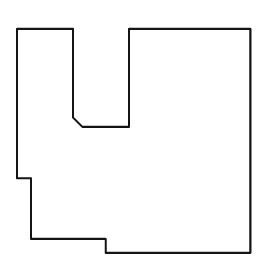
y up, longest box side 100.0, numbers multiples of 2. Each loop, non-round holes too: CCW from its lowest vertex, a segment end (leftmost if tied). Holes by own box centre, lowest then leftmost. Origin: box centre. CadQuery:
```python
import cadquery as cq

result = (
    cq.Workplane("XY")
    .moveTo(-12.0, -48.0)
    .lineTo(50.0, -48.0)
    .lineTo(50.0, 48.0)
    .lineTo(-2.0, 48.0)
    .lineTo(-2.0, 6.0)
    .lineTo(-22.0, 6.0)
    .lineTo(-26.0, 10.0)
    .lineTo(-26.0, 48.0)
    .lineTo(-50.0, 48.0)
    .lineTo(-50.0, -16.0)
    .lineTo(-44.0, -16.0)
    .lineTo(-44.0, -42.0)
    .lineTo(-12.0, -42.0)
    .close()
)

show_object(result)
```